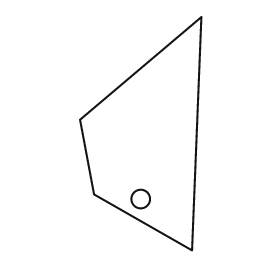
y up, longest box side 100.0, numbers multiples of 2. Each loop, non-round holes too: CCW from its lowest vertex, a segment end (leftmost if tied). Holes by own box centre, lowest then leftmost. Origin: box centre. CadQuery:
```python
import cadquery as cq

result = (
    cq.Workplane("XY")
    .moveTo(22.0, -50.0)
    .lineTo(26.0, 50.0)
    .lineTo(-26.0, 6.0)
    .lineTo(-20.0, -26.0)
    .close()
    .moveTo(0.0, -28.0)
    .circle(4.0)
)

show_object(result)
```